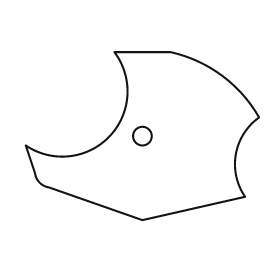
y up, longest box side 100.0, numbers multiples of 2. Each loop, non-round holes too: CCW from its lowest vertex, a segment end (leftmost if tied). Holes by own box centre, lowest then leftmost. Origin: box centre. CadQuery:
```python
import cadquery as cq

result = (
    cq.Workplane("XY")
    .moveTo(0.0, -36.0)
    .lineTo(44.0, -26.0)
    .threePointArc((40.0, -8.0), (50.0, 8.0))
    .threePointArc((34.0, 26.0), (12.0, 36.0))
    .lineTo(-12.0, 36.0)
    .threePointArc((-14.0, 0.0), (-50.0, -4.0))
    .lineTo(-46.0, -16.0)
    .threePointArc((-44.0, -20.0), (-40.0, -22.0))
    .close()
    .moveTo(0.0, 0.0)
    .circle(4.0)
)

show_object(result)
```